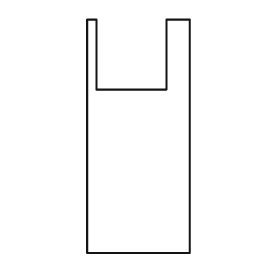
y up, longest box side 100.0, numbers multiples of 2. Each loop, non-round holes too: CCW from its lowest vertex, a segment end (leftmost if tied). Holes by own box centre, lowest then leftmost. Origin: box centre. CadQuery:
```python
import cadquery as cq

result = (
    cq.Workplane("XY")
    .moveTo(-22.0, -50.0)
    .lineTo(22.0, -50.0)
    .lineTo(22.0, 50.0)
    .lineTo(12.0, 50.0)
    .lineTo(12.0, 20.0)
    .lineTo(-18.0, 20.0)
    .lineTo(-18.0, 50.0)
    .lineTo(-22.0, 50.0)
    .close()
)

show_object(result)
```